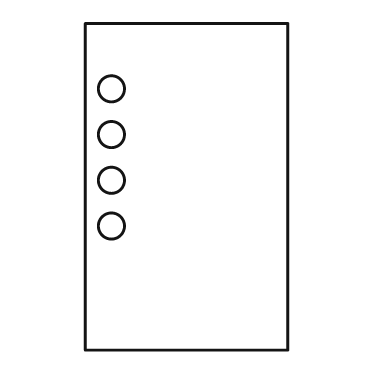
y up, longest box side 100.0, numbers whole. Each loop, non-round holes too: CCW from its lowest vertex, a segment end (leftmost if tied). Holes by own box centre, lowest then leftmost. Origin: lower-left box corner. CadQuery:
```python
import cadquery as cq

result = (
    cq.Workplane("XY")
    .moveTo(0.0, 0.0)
    .lineTo(62.0, 0.0)
    .lineTo(62.0, 100.0)
    .lineTo(0.0, 100.0)
    .close()
    .moveTo(8.0, 38.0)
    .circle(4.0)
    .moveTo(8.0, 52.0)
    .circle(4.0)
    .moveTo(8.0, 66.0)
    .circle(4.0)
    .moveTo(8.0, 80.0)
    .circle(4.0)
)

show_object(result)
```